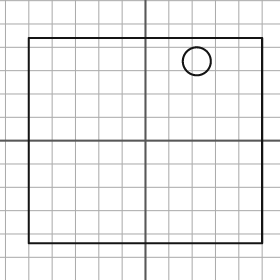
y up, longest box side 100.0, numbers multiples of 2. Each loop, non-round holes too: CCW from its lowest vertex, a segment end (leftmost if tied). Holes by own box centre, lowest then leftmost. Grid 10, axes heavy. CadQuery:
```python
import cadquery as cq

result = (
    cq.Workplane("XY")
    .moveTo(-50.0, -44.0)
    .lineTo(50.0, -44.0)
    .lineTo(50.0, 44.0)
    .lineTo(-50.0, 44.0)
    .close()
    .moveTo(22.0, 34.0)
    .circle(6.0)
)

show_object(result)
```